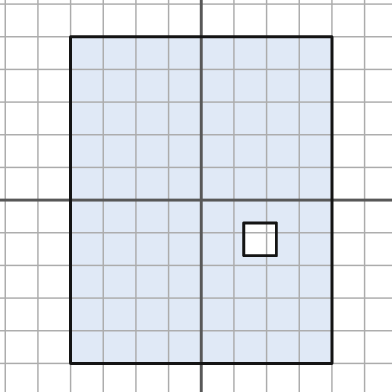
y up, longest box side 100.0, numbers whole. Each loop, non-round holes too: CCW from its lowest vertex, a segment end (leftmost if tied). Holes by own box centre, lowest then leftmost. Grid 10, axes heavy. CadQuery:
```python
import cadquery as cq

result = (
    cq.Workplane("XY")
    .moveTo(-40.0, -50.0)
    .lineTo(40.0, -50.0)
    .lineTo(40.0, 50.0)
    .lineTo(-40.0, 50.0)
    .close()
    .moveTo(13.0, -17.0)
    .lineTo(23.0, -17.0)
    .lineTo(23.0, -7.0)
    .lineTo(13.0, -7.0)
    .close()
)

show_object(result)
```